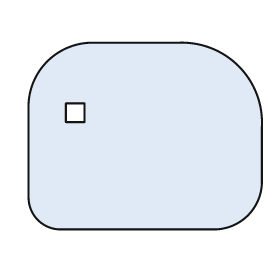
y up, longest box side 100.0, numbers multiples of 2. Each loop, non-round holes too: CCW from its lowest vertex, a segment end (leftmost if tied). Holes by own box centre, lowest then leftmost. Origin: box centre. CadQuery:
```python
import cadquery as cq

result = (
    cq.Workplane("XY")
    .moveTo(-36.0, -40.0)
    .lineTo(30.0, -40.0)
    .threePointArc((44.0, -34.0), (50.0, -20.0))
    .lineTo(50.0, 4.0)
    .threePointArc((40.0, 30.0), (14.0, 40.0))
    .lineTo(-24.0, 40.0)
    .threePointArc((-42.0, 32.0), (-50.0, 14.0))
    .lineTo(-50.0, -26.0)
    .threePointArc((-46.0, -36.0), (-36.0, -40.0))
    .close()
    .moveTo(-34.0, 6.0)
    .lineTo(-26.0, 6.0)
    .lineTo(-26.0, 14.0)
    .lineTo(-34.0, 14.0)
    .close()
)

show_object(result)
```